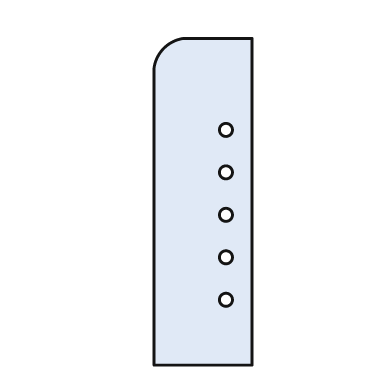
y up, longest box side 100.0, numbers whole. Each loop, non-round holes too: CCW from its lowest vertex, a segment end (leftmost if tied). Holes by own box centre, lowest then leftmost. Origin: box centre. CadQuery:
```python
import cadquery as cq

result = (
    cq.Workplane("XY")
    .moveTo(-15.0, -50.0)
    .lineTo(15.0, -50.0)
    .lineTo(15.0, 50.0)
    .lineTo(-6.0, 50.0)
    .threePointArc((-12.0, 47.0), (-15.0, 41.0))
    .close()
    .moveTo(7.0, -30.0)
    .circle(2.0)
    .moveTo(7.0, -17.0)
    .circle(2.0)
    .moveTo(7.0, -4.0)
    .circle(2.0)
    .moveTo(7.0, 9.0)
    .circle(2.0)
    .moveTo(7.0, 22.0)
    .circle(2.0)
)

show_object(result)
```